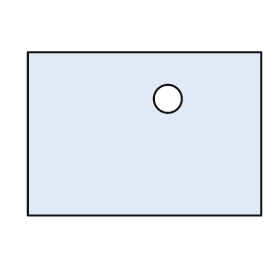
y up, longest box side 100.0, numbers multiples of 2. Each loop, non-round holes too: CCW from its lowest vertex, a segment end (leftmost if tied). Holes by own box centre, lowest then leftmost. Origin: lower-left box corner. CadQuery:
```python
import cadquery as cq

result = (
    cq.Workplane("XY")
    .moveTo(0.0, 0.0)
    .lineTo(100.0, 0.0)
    .lineTo(100.0, 70.0)
    .lineTo(0.0, 70.0)
    .close()
    .moveTo(60.0, 50.0)
    .circle(6.0)
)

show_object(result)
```